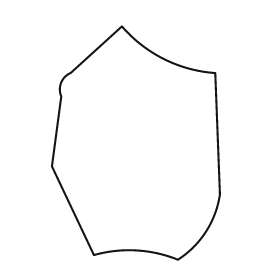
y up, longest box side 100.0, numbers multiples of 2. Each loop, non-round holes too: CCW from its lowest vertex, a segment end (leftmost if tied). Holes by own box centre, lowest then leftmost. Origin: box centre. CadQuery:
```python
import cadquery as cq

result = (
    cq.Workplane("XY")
    .moveTo(18.0, -50.0)
    .threePointArc((30.0, -38.0), (36.0, -22.0))
    .lineTo(34.0, 30.0)
    .threePointArc((12.0, 36.0), (-6.0, 50.0))
    .lineTo(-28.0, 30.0)
    .threePointArc((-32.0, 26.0), (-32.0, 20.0))
    .lineTo(-36.0, -10.0)
    .lineTo(-18.0, -48.0)
    .threePointArc((0.0, -46.0), (18.0, -50.0))
    .close()
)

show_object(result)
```